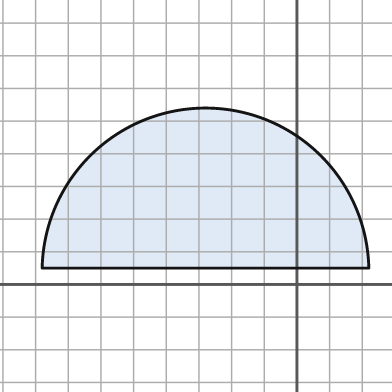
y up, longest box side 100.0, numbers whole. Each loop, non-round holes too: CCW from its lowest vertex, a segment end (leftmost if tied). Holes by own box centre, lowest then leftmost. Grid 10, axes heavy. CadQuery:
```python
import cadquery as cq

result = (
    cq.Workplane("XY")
    .moveTo(-78.0, 5.0)
    .lineTo(22.0, 5.0)
    .threePointArc((-28.0, 54.0), (-78.0, 5.0))
    .close()
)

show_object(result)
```